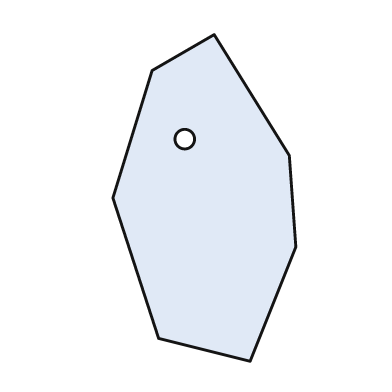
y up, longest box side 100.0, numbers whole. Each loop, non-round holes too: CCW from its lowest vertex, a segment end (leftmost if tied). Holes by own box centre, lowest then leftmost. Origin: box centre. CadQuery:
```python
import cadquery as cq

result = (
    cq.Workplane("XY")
    .moveTo(14.0, -50.0)
    .lineTo(28.0, -15.0)
    .lineTo(26.0, 13.0)
    .lineTo(3.0, 50.0)
    .lineTo(-16.0, 39.0)
    .lineTo(-28.0, 0.0)
    .lineTo(-14.0, -43.0)
    .close()
    .moveTo(-6.0, 18.0)
    .circle(3.0)
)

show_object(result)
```